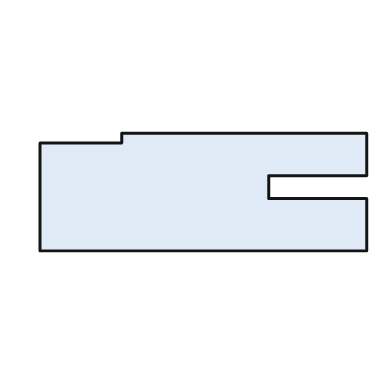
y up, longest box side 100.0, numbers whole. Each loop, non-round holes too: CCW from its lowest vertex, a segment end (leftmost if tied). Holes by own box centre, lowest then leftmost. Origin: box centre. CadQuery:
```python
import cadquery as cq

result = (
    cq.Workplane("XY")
    .moveTo(-50.0, -18.0)
    .lineTo(50.0, -18.0)
    .lineTo(50.0, -2.0)
    .lineTo(20.0, -2.0)
    .lineTo(20.0, 5.0)
    .lineTo(50.0, 5.0)
    .lineTo(50.0, 18.0)
    .lineTo(-25.0, 18.0)
    .lineTo(-25.0, 15.0)
    .lineTo(-50.0, 15.0)
    .close()
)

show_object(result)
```